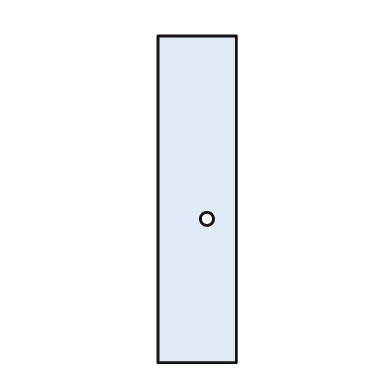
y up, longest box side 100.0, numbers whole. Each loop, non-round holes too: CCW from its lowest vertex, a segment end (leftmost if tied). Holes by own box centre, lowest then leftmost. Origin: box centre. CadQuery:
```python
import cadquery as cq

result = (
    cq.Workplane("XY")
    .moveTo(-12.0, -50.0)
    .lineTo(12.0, -50.0)
    .lineTo(12.0, 50.0)
    .lineTo(-12.0, 50.0)
    .close()
    .moveTo(3.0, -6.0)
    .circle(2.0)
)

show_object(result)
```